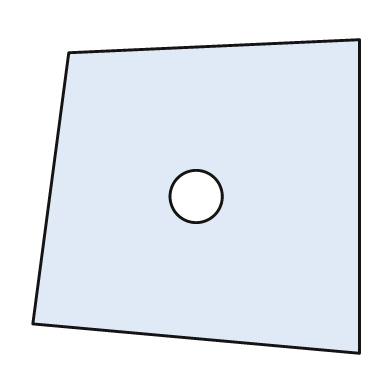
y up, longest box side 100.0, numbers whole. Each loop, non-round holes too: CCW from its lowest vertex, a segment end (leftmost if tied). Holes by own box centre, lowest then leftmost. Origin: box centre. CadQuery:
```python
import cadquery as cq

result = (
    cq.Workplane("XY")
    .moveTo(50.0, -48.0)
    .lineTo(50.0, 48.0)
    .lineTo(-39.0, 44.0)
    .lineTo(-50.0, -39.0)
    .close()
    .moveTo(0.0, 0.0)
    .circle(8.0)
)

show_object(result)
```